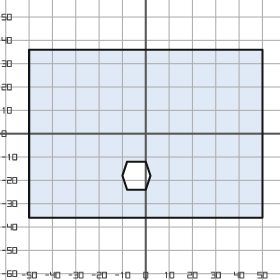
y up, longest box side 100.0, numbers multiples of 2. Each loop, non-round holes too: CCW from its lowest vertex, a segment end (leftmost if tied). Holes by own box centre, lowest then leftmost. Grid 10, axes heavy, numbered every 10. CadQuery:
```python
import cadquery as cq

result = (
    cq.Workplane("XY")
    .moveTo(-50.0, -36.0)
    .lineTo(50.0, -36.0)
    .lineTo(50.0, 36.0)
    .lineTo(-50.0, 36.0)
    .close()
    .moveTo(-8.0, -24.0)
    .lineTo(0.0, -24.0)
    .lineTo(2.0, -18.0)
    .lineTo(0.0, -12.0)
    .lineTo(-8.0, -12.0)
    .lineTo(-10.0, -18.0)
    .close()
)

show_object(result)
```